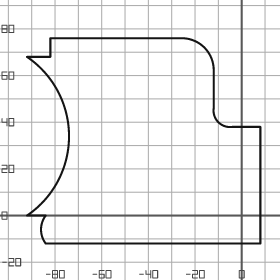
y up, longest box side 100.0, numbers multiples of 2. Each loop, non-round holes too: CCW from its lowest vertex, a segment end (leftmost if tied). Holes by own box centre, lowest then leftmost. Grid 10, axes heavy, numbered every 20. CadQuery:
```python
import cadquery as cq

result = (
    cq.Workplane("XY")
    .moveTo(-84.0, -12.0)
    .lineTo(8.0, -12.0)
    .lineTo(8.0, 38.0)
    .lineTo(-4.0, 38.0)
    .threePointArc((-10.0, 40.0), (-12.0, 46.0))
    .lineTo(-12.0, 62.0)
    .threePointArc((-16.0, 72.0), (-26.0, 76.0))
    .lineTo(-82.0, 76.0)
    .lineTo(-82.0, 68.0)
    .lineTo(-92.0, 68.0)
    .threePointArc((-74.0, 34.0), (-92.0, 0.0))
    .lineTo(-84.0, 0.0)
    .threePointArc((-86.0, -6.0), (-84.0, -12.0))
    .close()
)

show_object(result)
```